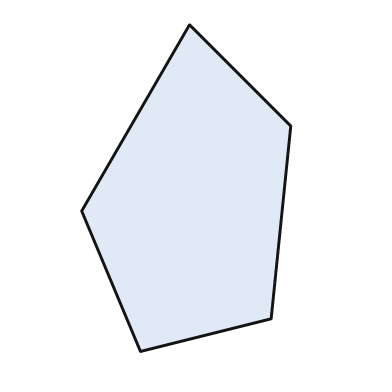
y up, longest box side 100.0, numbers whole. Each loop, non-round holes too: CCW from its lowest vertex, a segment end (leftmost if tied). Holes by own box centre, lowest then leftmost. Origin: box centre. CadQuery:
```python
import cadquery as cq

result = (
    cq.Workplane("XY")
    .moveTo(-14.0, -50.0)
    .lineTo(26.0, -40.0)
    .lineTo(32.0, 19.0)
    .lineTo(1.0, 50.0)
    .lineTo(-32.0, -7.0)
    .close()
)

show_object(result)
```